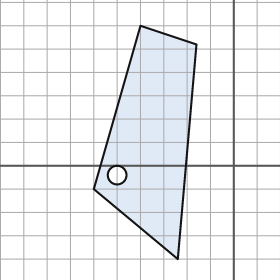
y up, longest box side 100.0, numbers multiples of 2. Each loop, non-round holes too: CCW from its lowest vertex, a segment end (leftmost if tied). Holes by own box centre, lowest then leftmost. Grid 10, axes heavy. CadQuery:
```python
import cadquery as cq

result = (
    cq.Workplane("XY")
    .moveTo(-24.0, -40.0)
    .lineTo(-16.0, 52.0)
    .lineTo(-40.0, 60.0)
    .lineTo(-60.0, -10.0)
    .close()
    .moveTo(-50.0, -4.0)
    .circle(4.0)
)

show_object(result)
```